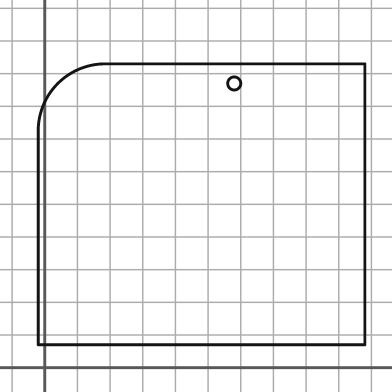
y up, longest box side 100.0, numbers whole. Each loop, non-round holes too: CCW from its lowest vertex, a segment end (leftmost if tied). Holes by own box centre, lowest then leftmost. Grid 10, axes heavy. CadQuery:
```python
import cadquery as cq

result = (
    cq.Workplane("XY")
    .moveTo(-2.0, 7.0)
    .lineTo(98.0, 7.0)
    .lineTo(98.0, 93.0)
    .lineTo(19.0, 93.0)
    .threePointArc((4.0, 87.0), (-2.0, 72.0))
    .close()
    .moveTo(58.0, 87.0)
    .circle(2.0)
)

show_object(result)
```